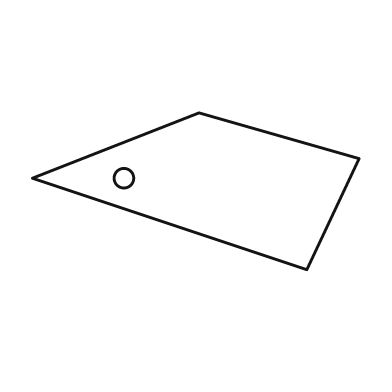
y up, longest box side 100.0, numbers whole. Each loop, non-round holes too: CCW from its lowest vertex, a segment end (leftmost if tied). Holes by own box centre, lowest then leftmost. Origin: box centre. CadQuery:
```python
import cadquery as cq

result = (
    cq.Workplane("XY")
    .moveTo(34.0, -24.0)
    .lineTo(50.0, 10.0)
    .lineTo(1.0, 24.0)
    .lineTo(-50.0, 4.0)
    .close()
    .moveTo(-22.0, 4.0)
    .circle(3.0)
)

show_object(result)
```